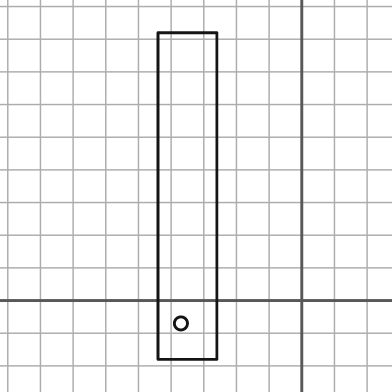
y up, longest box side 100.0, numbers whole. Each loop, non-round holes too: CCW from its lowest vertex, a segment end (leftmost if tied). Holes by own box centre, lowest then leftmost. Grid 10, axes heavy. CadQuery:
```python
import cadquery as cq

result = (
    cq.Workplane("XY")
    .moveTo(-44.0, -18.0)
    .lineTo(-26.0, -18.0)
    .lineTo(-26.0, 82.0)
    .lineTo(-44.0, 82.0)
    .close()
    .moveTo(-37.0, -7.0)
    .circle(2.0)
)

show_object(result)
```